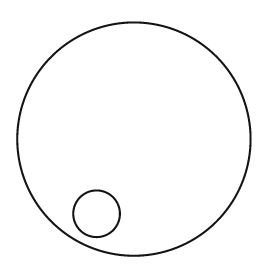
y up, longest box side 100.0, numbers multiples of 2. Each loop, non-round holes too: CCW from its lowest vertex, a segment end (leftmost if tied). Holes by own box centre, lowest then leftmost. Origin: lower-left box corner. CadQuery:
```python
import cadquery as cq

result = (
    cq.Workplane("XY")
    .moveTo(50.0, 50.0)
    .circle(50.0)
    .moveTo(34.0, 18.0)
    .circle(10.0)
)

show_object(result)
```